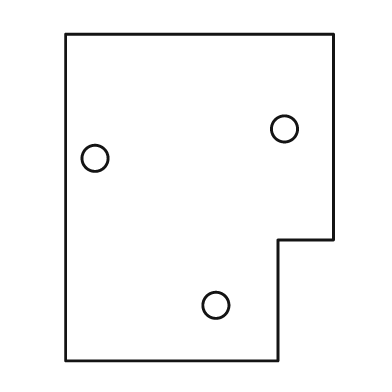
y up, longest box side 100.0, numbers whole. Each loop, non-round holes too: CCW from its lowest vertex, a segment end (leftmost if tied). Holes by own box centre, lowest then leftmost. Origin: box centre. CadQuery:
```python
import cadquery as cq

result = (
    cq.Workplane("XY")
    .moveTo(-41.0, -50.0)
    .lineTo(24.0, -50.0)
    .lineTo(24.0, -13.0)
    .lineTo(41.0, -13.0)
    .lineTo(41.0, 50.0)
    .lineTo(-41.0, 50.0)
    .close()
    .moveTo(5.0, -33.0)
    .circle(4.0)
    .moveTo(-32.0, 12.0)
    .circle(4.0)
    .moveTo(26.0, 21.0)
    .circle(4.0)
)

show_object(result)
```